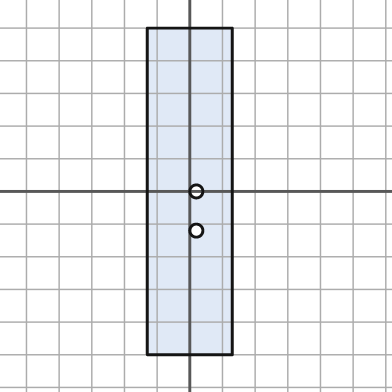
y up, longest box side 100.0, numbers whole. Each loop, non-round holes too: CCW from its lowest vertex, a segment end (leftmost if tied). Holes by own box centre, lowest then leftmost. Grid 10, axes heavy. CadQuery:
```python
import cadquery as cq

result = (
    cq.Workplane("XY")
    .moveTo(-13.0, -50.0)
    .lineTo(13.0, -50.0)
    .lineTo(13.0, 50.0)
    .lineTo(-13.0, 50.0)
    .close()
    .moveTo(2.0, -12.0)
    .circle(2.0)
    .moveTo(2.0, 0.0)
    .circle(2.0)
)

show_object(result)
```